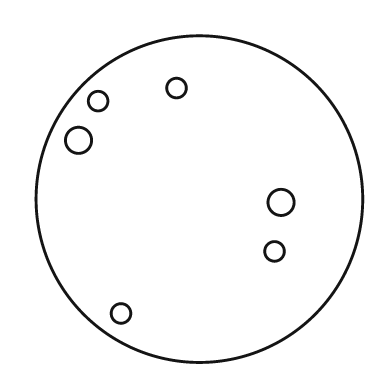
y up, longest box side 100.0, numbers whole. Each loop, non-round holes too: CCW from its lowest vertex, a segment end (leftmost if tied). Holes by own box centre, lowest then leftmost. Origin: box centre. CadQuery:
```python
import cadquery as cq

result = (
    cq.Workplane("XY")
    .moveTo(0.0, 0.0)
    .circle(50.0)
    .moveTo(-24.0, -35.0)
    .circle(3.0)
    .moveTo(23.0, -16.0)
    .circle(3.0)
    .moveTo(25.0, -1.0)
    .circle(4.0)
    .moveTo(-37.0, 18.0)
    .circle(4.0)
    .moveTo(-31.0, 30.0)
    .circle(3.0)
    .moveTo(-7.0, 34.0)
    .circle(3.0)
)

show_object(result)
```